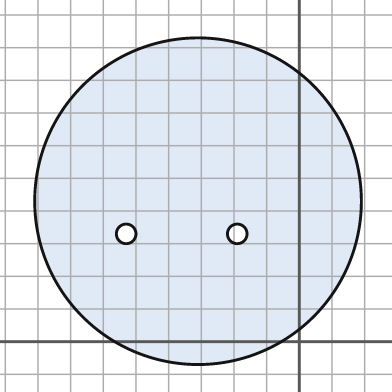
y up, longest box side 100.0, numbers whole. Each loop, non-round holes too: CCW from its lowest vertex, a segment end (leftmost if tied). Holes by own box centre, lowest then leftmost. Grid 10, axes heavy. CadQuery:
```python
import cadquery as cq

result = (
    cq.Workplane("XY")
    .moveTo(-31.0, 43.0)
    .circle(50.0)
    .moveTo(-53.0, 33.0)
    .circle(3.0)
    .moveTo(-19.0, 33.0)
    .circle(3.0)
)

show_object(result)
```